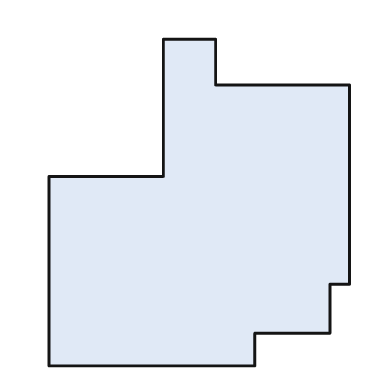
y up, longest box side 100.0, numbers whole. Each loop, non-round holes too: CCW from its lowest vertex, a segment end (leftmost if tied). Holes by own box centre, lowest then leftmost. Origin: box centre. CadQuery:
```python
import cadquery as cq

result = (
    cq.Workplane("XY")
    .moveTo(-46.0, -50.0)
    .lineTo(17.0, -50.0)
    .lineTo(17.0, -40.0)
    .lineTo(40.0, -40.0)
    .lineTo(40.0, -25.0)
    .lineTo(46.0, -25.0)
    .lineTo(46.0, 36.0)
    .lineTo(5.0, 36.0)
    .lineTo(5.0, 50.0)
    .lineTo(-11.0, 50.0)
    .lineTo(-11.0, 8.0)
    .lineTo(-46.0, 8.0)
    .close()
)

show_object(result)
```